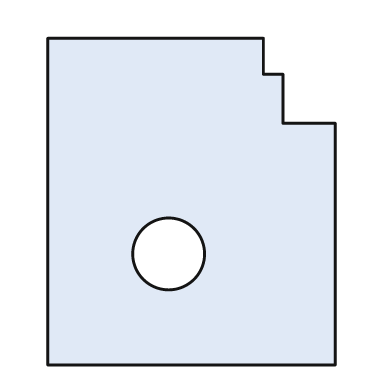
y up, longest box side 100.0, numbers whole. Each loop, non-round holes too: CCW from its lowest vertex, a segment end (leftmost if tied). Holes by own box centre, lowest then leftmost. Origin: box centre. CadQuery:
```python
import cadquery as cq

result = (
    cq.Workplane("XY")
    .moveTo(-44.0, -50.0)
    .lineTo(44.0, -50.0)
    .lineTo(44.0, 24.0)
    .lineTo(28.0, 24.0)
    .lineTo(28.0, 39.0)
    .lineTo(22.0, 39.0)
    .lineTo(22.0, 50.0)
    .lineTo(-44.0, 50.0)
    .close()
    .moveTo(-7.0, -16.0)
    .circle(11.0)
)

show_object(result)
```